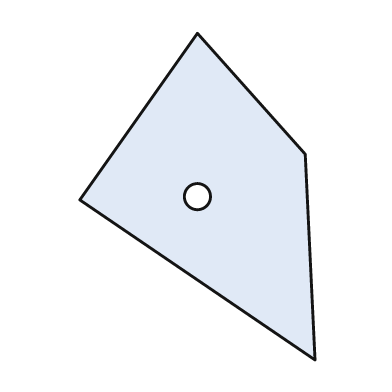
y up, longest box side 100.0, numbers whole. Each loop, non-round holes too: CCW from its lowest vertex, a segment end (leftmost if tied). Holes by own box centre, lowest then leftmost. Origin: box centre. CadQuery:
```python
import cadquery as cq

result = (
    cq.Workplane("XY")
    .moveTo(36.0, -50.0)
    .lineTo(33.0, 13.0)
    .lineTo(0.0, 50.0)
    .lineTo(-36.0, -1.0)
    .close()
    .moveTo(0.0, 0.0)
    .circle(4.0)
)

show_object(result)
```